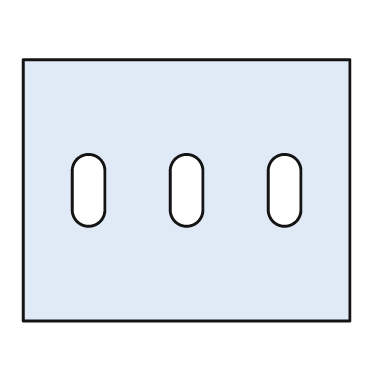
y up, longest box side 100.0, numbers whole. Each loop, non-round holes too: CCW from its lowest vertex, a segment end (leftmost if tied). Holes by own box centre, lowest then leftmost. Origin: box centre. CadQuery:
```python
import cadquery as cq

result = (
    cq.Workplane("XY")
    .moveTo(-50.0, -40.0)
    .lineTo(50.0, -40.0)
    .lineTo(50.0, 40.0)
    .lineTo(-50.0, 40.0)
    .close()
    .moveTo(-35.0, -6.0)
    .threePointArc((-30.0, -11.0), (-25.0, -6.0))
    .lineTo(-25.0, 6.0)
    .threePointArc((-30.0, 11.0), (-35.0, 6.0))
    .close()
    .moveTo(-5.0, -6.0)
    .threePointArc((0.0, -11.0), (5.0, -6.0))
    .lineTo(5.0, 6.0)
    .threePointArc((0.0, 11.0), (-5.0, 6.0))
    .close()
    .moveTo(25.0, -6.0)
    .threePointArc((30.0, -11.0), (35.0, -6.0))
    .lineTo(35.0, 6.0)
    .threePointArc((30.0, 11.0), (25.0, 6.0))
    .close()
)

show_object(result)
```